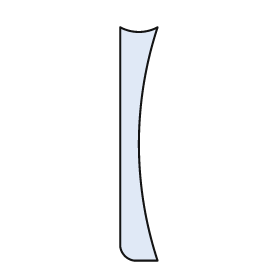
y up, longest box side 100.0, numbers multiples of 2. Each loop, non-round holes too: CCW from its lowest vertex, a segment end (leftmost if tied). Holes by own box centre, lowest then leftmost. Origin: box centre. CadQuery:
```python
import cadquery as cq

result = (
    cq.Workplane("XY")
    .moveTo(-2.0, -50.0)
    .lineTo(8.0, -50.0)
    .threePointArc((0.0, 0.0), (8.0, 50.0))
    .threePointArc((0.0, 48.0), (-8.0, 50.0))
    .lineTo(-8.0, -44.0)
    .threePointArc((-6.0, -48.0), (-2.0, -50.0))
    .close()
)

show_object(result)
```